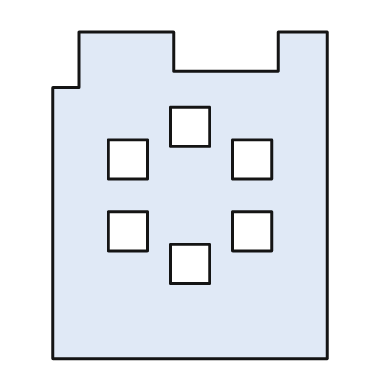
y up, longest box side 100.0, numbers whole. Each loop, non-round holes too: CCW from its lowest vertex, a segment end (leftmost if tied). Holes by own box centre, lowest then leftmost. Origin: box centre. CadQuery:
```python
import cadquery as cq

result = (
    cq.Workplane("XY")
    .moveTo(-42.0, -50.0)
    .lineTo(42.0, -50.0)
    .lineTo(42.0, 50.0)
    .lineTo(27.0, 50.0)
    .lineTo(27.0, 38.0)
    .lineTo(-5.0, 38.0)
    .lineTo(-5.0, 50.0)
    .lineTo(-34.0, 50.0)
    .lineTo(-34.0, 33.0)
    .lineTo(-42.0, 33.0)
    .close()
    .moveTo(-6.0, -27.0)
    .lineTo(6.0, -27.0)
    .lineTo(6.0, -15.0)
    .lineTo(-6.0, -15.0)
    .close()
    .moveTo(-25.0, -17.0)
    .lineTo(-13.0, -17.0)
    .lineTo(-13.0, -5.0)
    .lineTo(-25.0, -5.0)
    .close()
    .moveTo(13.0, -17.0)
    .lineTo(25.0, -17.0)
    .lineTo(25.0, -5.0)
    .lineTo(13.0, -5.0)
    .close()
    .moveTo(-25.0, 5.0)
    .lineTo(-13.0, 5.0)
    .lineTo(-13.0, 17.0)
    .lineTo(-25.0, 17.0)
    .close()
    .moveTo(13.0, 5.0)
    .lineTo(25.0, 5.0)
    .lineTo(25.0, 17.0)
    .lineTo(13.0, 17.0)
    .close()
    .moveTo(-6.0, 15.0)
    .lineTo(6.0, 15.0)
    .lineTo(6.0, 27.0)
    .lineTo(-6.0, 27.0)
    .close()
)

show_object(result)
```